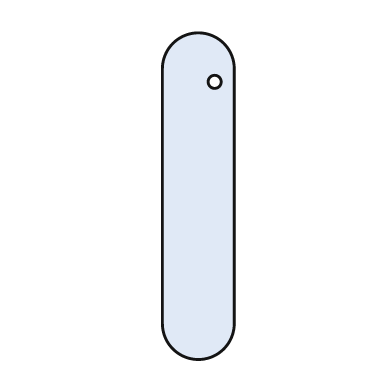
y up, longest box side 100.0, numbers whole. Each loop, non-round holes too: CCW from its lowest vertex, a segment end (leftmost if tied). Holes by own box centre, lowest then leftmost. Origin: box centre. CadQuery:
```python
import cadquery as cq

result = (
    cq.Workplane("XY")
    .moveTo(-11.0, -39.0)
    .threePointArc((0.0, -50.0), (11.0, -39.0))
    .lineTo(11.0, 39.0)
    .threePointArc((0.0, 50.0), (-11.0, 39.0))
    .close()
    .moveTo(5.0, 35.0)
    .circle(2.0)
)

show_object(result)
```